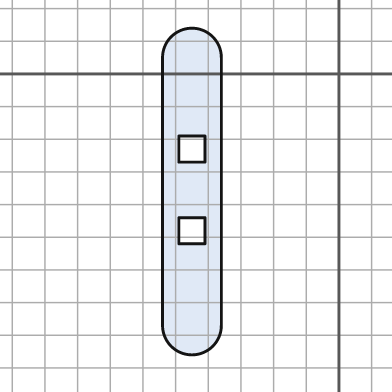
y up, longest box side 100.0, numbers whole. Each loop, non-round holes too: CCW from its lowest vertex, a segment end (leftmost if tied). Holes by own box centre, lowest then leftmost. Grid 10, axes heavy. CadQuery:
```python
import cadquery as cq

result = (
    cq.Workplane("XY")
    .moveTo(-54.0, -77.0)
    .threePointArc((-45.0, -86.0), (-36.0, -77.0))
    .lineTo(-36.0, 5.0)
    .threePointArc((-45.0, 14.0), (-54.0, 5.0))
    .close()
    .moveTo(-49.0, -52.0)
    .lineTo(-41.0, -52.0)
    .lineTo(-41.0, -44.0)
    .lineTo(-49.0, -44.0)
    .close()
    .moveTo(-49.0, -27.0)
    .lineTo(-41.0, -27.0)
    .lineTo(-41.0, -19.0)
    .lineTo(-49.0, -19.0)
    .close()
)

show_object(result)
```